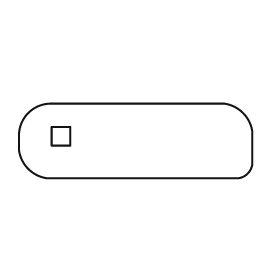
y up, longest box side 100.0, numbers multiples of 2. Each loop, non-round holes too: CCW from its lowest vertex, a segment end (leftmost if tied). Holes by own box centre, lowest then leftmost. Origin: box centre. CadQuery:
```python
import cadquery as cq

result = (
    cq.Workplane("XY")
    .moveTo(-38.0, -16.0)
    .lineTo(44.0, -16.0)
    .threePointArc((48.0, -14.0), (50.0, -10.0))
    .lineTo(50.0, 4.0)
    .threePointArc((46.0, 12.0), (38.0, 16.0))
    .lineTo(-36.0, 16.0)
    .threePointArc((-46.0, 12.0), (-50.0, 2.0))
    .lineTo(-50.0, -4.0)
    .threePointArc((-46.0, -12.0), (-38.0, -16.0))
    .close()
    .moveTo(-36.0, -2.0)
    .lineTo(-28.0, -2.0)
    .lineTo(-28.0, 6.0)
    .lineTo(-36.0, 6.0)
    .close()
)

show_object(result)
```